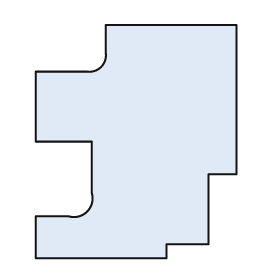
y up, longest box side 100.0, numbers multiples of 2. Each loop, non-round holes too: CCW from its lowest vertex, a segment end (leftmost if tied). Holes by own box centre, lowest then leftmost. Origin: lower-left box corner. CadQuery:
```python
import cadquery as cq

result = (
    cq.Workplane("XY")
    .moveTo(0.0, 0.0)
    .lineTo(56.0, 0.0)
    .lineTo(56.0, 6.0)
    .lineTo(74.0, 6.0)
    .lineTo(74.0, 36.0)
    .lineTo(86.0, 36.0)
    .lineTo(86.0, 100.0)
    .lineTo(30.0, 100.0)
    .lineTo(30.0, 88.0)
    .threePointArc((28.0, 82.0), (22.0, 80.0))
    .lineTo(0.0, 80.0)
    .lineTo(0.0, 50.0)
    .lineTo(24.0, 50.0)
    .lineTo(24.0, 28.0)
    .threePointArc((22.0, 20.0), (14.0, 18.0))
    .lineTo(0.0, 18.0)
    .close()
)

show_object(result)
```